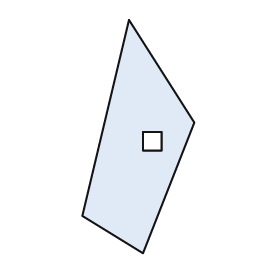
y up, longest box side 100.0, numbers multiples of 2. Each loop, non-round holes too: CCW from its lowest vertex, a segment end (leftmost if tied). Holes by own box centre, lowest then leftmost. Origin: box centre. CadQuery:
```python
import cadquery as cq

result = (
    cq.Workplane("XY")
    .moveTo(2.0, -50.0)
    .lineTo(24.0, 6.0)
    .lineTo(-4.0, 50.0)
    .lineTo(-24.0, -34.0)
    .close()
    .moveTo(2.0, -6.0)
    .lineTo(10.0, -6.0)
    .lineTo(10.0, 2.0)
    .lineTo(2.0, 2.0)
    .close()
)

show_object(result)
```